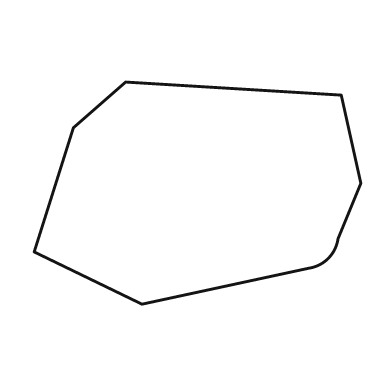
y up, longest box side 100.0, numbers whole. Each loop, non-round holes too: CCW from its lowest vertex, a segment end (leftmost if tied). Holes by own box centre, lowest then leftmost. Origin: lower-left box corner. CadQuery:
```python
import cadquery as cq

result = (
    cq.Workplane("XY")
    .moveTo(33.0, 0.0)
    .lineTo(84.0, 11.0)
    .threePointArc((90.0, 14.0), (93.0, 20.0))
    .lineTo(100.0, 37.0)
    .lineTo(94.0, 64.0)
    .lineTo(28.0, 68.0)
    .lineTo(12.0, 54.0)
    .lineTo(0.0, 16.0)
    .close()
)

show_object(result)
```